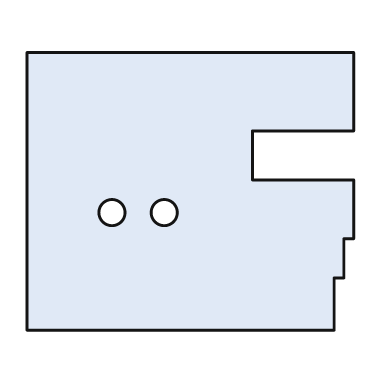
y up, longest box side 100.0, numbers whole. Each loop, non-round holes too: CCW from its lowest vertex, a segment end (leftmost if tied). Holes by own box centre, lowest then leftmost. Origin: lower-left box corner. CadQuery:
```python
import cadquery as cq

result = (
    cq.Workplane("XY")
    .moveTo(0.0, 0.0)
    .lineTo(94.0, 0.0)
    .lineTo(94.0, 16.0)
    .lineTo(97.0, 16.0)
    .lineTo(97.0, 28.0)
    .lineTo(100.0, 28.0)
    .lineTo(100.0, 46.0)
    .lineTo(69.0, 46.0)
    .lineTo(69.0, 61.0)
    .lineTo(100.0, 61.0)
    .lineTo(100.0, 85.0)
    .lineTo(0.0, 85.0)
    .close()
    .moveTo(26.0, 36.0)
    .circle(4.0)
    .moveTo(42.0, 36.0)
    .circle(4.0)
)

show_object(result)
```